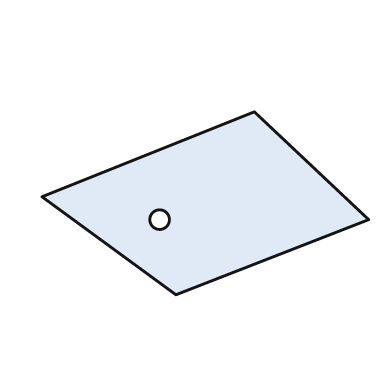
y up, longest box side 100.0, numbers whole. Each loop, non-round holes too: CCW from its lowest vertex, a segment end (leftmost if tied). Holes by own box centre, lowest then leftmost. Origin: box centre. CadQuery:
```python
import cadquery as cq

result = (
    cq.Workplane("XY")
    .moveTo(-9.0, -28.0)
    .lineTo(50.0, -5.0)
    .lineTo(15.0, 28.0)
    .lineTo(-50.0, 2.0)
    .close()
    .moveTo(-14.0, -5.0)
    .circle(3.0)
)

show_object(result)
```